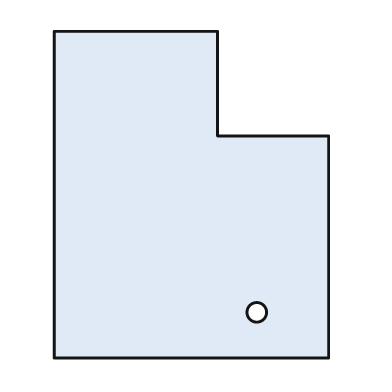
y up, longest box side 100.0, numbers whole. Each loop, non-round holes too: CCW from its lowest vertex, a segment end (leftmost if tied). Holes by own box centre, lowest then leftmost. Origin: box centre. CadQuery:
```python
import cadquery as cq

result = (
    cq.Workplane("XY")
    .moveTo(-42.0, -50.0)
    .lineTo(42.0, -50.0)
    .lineTo(42.0, 18.0)
    .lineTo(8.0, 18.0)
    .lineTo(8.0, 50.0)
    .lineTo(-42.0, 50.0)
    .close()
    .moveTo(20.0, -36.0)
    .circle(3.0)
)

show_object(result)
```